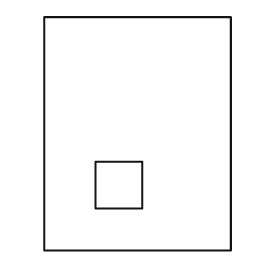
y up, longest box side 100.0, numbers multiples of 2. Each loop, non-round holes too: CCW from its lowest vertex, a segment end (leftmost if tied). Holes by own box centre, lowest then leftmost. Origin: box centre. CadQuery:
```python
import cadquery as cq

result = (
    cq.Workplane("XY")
    .moveTo(-40.0, -50.0)
    .lineTo(40.0, -50.0)
    .lineTo(40.0, 50.0)
    .lineTo(-40.0, 50.0)
    .close()
    .moveTo(-18.0, -32.0)
    .lineTo(2.0, -32.0)
    .lineTo(2.0, -12.0)
    .lineTo(-18.0, -12.0)
    .close()
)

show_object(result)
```